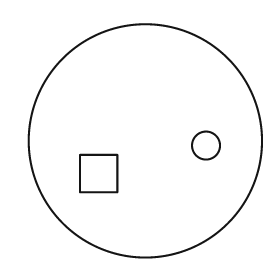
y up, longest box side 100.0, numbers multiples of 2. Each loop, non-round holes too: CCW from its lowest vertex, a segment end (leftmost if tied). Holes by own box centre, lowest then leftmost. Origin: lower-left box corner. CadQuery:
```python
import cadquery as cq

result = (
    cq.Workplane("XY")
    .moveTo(50.0, 50.0)
    .circle(50.0)
    .moveTo(22.0, 28.0)
    .lineTo(38.0, 28.0)
    .lineTo(38.0, 44.0)
    .lineTo(22.0, 44.0)
    .close()
    .moveTo(76.0, 48.0)
    .circle(6.0)
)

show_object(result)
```